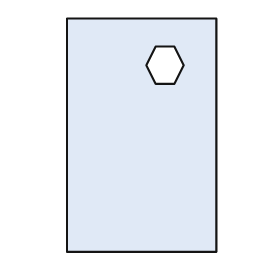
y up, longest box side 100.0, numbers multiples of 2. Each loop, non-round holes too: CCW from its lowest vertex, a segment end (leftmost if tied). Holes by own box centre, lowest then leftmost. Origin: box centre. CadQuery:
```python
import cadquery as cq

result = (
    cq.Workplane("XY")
    .moveTo(-32.0, -50.0)
    .lineTo(32.0, -50.0)
    .lineTo(32.0, 50.0)
    .lineTo(-32.0, 50.0)
    .close()
    .moveTo(6.0, 22.0)
    .lineTo(14.0, 22.0)
    .lineTo(18.0, 30.0)
    .lineTo(14.0, 38.0)
    .lineTo(6.0, 38.0)
    .lineTo(2.0, 30.0)
    .close()
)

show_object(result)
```